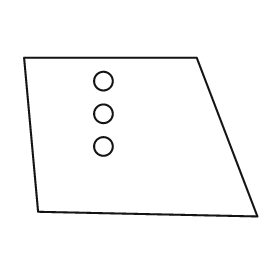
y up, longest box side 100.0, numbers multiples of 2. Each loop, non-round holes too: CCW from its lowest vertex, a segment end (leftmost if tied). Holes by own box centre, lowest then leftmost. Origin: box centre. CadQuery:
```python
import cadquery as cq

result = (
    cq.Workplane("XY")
    .moveTo(50.0, -34.0)
    .lineTo(24.0, 34.0)
    .lineTo(-50.0, 34.0)
    .lineTo(-44.0, -32.0)
    .close()
    .moveTo(-16.0, -4.0)
    .circle(4.0)
    .moveTo(-16.0, 10.0)
    .circle(4.0)
    .moveTo(-16.0, 24.0)
    .circle(4.0)
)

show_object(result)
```